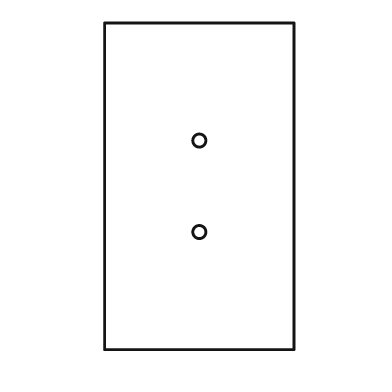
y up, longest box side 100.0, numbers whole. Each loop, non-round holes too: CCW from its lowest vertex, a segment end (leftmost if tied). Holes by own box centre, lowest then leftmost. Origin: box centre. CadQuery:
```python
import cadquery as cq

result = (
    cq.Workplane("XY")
    .moveTo(-29.0, -50.0)
    .lineTo(29.0, -50.0)
    .lineTo(29.0, 50.0)
    .lineTo(-29.0, 50.0)
    .close()
    .moveTo(0.0, -14.0)
    .circle(2.0)
    .moveTo(0.0, 14.0)
    .circle(2.0)
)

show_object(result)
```